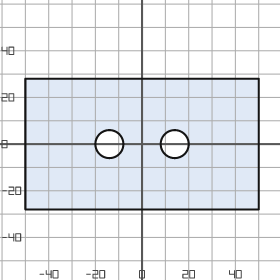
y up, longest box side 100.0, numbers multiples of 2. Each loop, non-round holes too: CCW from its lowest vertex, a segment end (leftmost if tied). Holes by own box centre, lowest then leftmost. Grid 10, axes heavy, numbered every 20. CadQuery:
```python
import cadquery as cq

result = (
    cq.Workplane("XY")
    .moveTo(-50.0, -28.0)
    .lineTo(50.0, -28.0)
    .lineTo(50.0, 28.0)
    .lineTo(-50.0, 28.0)
    .close()
    .moveTo(-14.0, 0.0)
    .circle(6.0)
    .moveTo(14.0, 0.0)
    .circle(6.0)
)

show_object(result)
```